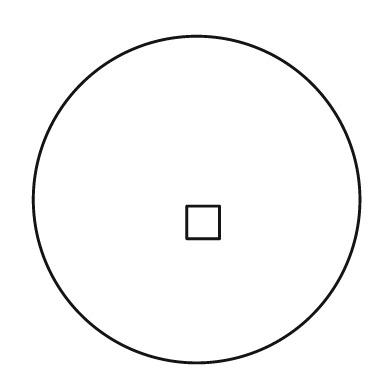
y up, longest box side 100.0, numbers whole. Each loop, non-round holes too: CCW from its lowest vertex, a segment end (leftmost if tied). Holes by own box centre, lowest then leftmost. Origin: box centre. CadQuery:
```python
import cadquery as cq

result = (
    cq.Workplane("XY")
    .moveTo(0.0, 0.0)
    .circle(50.0)
    .moveTo(-3.0, -12.0)
    .lineTo(7.0, -12.0)
    .lineTo(7.0, -2.0)
    .lineTo(-3.0, -2.0)
    .close()
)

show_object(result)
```